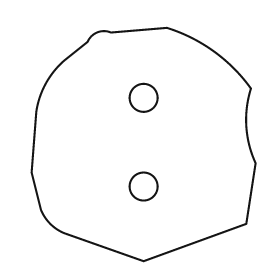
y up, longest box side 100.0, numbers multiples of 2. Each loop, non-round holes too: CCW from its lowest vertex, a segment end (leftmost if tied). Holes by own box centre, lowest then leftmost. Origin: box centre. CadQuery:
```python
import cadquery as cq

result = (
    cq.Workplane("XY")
    .moveTo(0.0, -50.0)
    .lineTo(44.0, -34.0)
    .lineTo(48.0, -8.0)
    .threePointArc((44.0, 8.0), (46.0, 24.0))
    .threePointArc((30.0, 40.0), (10.0, 50.0))
    .lineTo(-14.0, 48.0)
    .threePointArc((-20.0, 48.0), (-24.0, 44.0))
    .lineTo(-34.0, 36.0)
    .threePointArc((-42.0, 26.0), (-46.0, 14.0))
    .lineTo(-48.0, -12.0)
    .lineTo(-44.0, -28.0)
    .threePointArc((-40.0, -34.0), (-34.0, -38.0))
    .close()
    .moveTo(0.0, -18.0)
    .circle(6.0)
    .moveTo(0.0, 20.0)
    .circle(6.0)
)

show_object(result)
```